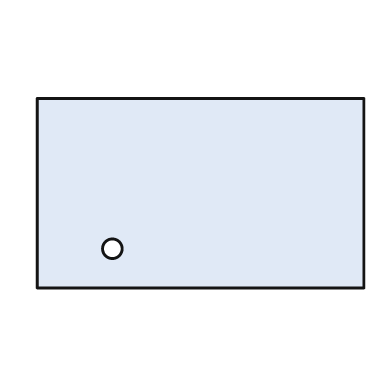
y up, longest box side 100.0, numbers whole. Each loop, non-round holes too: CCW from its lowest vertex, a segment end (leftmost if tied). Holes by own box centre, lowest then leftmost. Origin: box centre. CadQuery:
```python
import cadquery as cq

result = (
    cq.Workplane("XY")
    .moveTo(-50.0, -29.0)
    .lineTo(50.0, -29.0)
    .lineTo(50.0, 29.0)
    .lineTo(-50.0, 29.0)
    .close()
    .moveTo(-27.0, -17.0)
    .circle(3.0)
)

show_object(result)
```